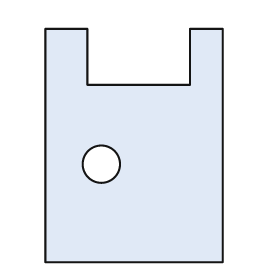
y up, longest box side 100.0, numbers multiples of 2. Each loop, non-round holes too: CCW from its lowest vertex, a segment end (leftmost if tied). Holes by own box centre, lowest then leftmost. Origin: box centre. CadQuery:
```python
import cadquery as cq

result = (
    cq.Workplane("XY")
    .moveTo(-38.0, -50.0)
    .lineTo(38.0, -50.0)
    .lineTo(38.0, 50.0)
    .lineTo(24.0, 50.0)
    .lineTo(24.0, 26.0)
    .lineTo(-20.0, 26.0)
    .lineTo(-20.0, 50.0)
    .lineTo(-38.0, 50.0)
    .close()
    .moveTo(-14.0, -8.0)
    .circle(8.0)
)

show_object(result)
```